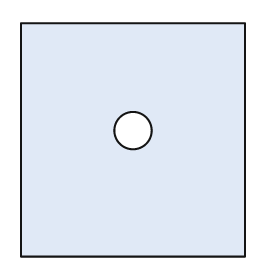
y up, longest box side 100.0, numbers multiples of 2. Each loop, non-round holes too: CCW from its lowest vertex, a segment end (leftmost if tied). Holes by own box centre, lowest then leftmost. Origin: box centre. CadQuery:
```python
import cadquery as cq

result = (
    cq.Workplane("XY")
    .moveTo(-48.0, -50.0)
    .lineTo(48.0, -50.0)
    .lineTo(48.0, 50.0)
    .lineTo(-48.0, 50.0)
    .close()
    .moveTo(0.0, 4.0)
    .circle(8.0)
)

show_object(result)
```